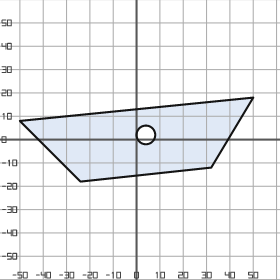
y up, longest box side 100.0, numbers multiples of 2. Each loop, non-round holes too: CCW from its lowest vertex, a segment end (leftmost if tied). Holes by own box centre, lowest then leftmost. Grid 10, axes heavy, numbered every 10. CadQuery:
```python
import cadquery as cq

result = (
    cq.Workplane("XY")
    .moveTo(-24.0, -18.0)
    .lineTo(32.0, -12.0)
    .lineTo(50.0, 18.0)
    .lineTo(-50.0, 8.0)
    .close()
    .moveTo(4.0, 2.0)
    .circle(4.0)
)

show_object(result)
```